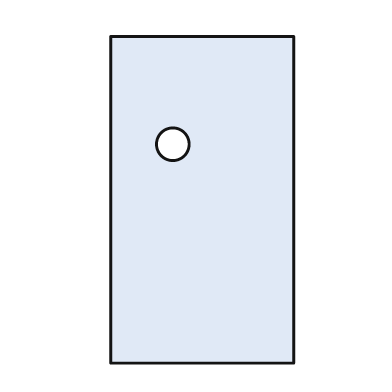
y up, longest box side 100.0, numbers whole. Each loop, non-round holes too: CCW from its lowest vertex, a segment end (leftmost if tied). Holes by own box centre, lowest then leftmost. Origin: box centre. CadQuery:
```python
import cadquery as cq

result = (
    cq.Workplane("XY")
    .moveTo(-28.0, -50.0)
    .lineTo(28.0, -50.0)
    .lineTo(28.0, 50.0)
    .lineTo(-28.0, 50.0)
    .close()
    .moveTo(-9.0, 17.0)
    .circle(5.0)
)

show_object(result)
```